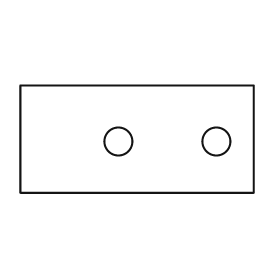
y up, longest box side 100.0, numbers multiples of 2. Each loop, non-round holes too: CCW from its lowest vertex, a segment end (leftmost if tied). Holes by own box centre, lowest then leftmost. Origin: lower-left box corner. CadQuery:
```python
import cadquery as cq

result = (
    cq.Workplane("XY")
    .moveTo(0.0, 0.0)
    .lineTo(100.0, 0.0)
    .lineTo(100.0, 46.0)
    .lineTo(0.0, 46.0)
    .close()
    .moveTo(42.0, 22.0)
    .circle(6.0)
    .moveTo(84.0, 22.0)
    .circle(6.0)
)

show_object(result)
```